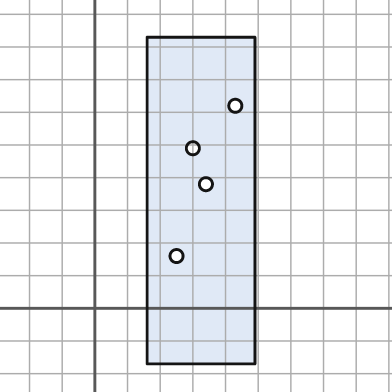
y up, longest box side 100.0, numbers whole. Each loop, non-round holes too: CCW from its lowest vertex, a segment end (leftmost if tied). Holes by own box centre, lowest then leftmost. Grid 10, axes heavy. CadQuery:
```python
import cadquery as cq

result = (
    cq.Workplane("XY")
    .moveTo(16.0, -17.0)
    .lineTo(49.0, -17.0)
    .lineTo(49.0, 83.0)
    .lineTo(16.0, 83.0)
    .close()
    .moveTo(25.0, 16.0)
    .circle(2.0)
    .moveTo(34.0, 38.0)
    .circle(2.0)
    .moveTo(30.0, 49.0)
    .circle(2.0)
    .moveTo(43.0, 62.0)
    .circle(2.0)
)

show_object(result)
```